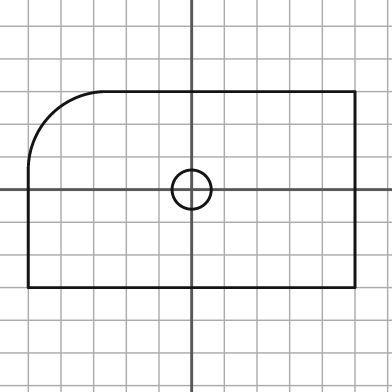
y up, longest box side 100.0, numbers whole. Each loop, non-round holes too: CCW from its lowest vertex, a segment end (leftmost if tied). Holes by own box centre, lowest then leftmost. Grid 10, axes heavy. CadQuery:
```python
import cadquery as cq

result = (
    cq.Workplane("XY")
    .moveTo(-50.0, -30.0)
    .lineTo(50.0, -30.0)
    .lineTo(50.0, 30.0)
    .lineTo(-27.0, 30.0)
    .threePointArc((-43.0, 23.0), (-50.0, 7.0))
    .close()
    .moveTo(0.0, 0.0)
    .circle(6.0)
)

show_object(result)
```